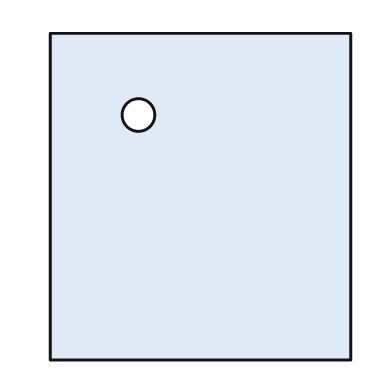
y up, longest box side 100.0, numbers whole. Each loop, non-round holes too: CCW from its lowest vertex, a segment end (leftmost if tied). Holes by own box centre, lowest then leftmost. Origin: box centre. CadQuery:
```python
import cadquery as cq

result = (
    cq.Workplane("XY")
    .moveTo(-46.0, -50.0)
    .lineTo(46.0, -50.0)
    .lineTo(46.0, 50.0)
    .lineTo(-46.0, 50.0)
    .close()
    .moveTo(-19.0, 25.0)
    .circle(5.0)
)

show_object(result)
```